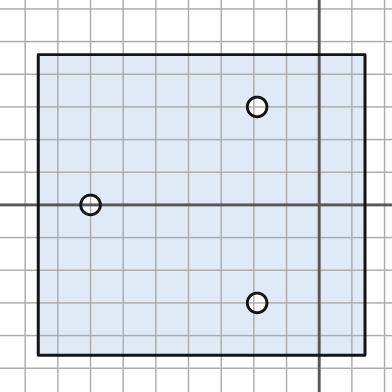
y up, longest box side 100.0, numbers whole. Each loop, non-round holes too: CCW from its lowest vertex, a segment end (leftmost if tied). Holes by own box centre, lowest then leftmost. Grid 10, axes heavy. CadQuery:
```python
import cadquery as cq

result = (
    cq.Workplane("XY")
    .moveTo(-86.0, -46.0)
    .lineTo(14.0, -46.0)
    .lineTo(14.0, 46.0)
    .lineTo(-86.0, 46.0)
    .close()
    .moveTo(-19.0, -30.0)
    .circle(3.0)
    .moveTo(-70.0, 0.0)
    .circle(3.0)
    .moveTo(-19.0, 30.0)
    .circle(3.0)
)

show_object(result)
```